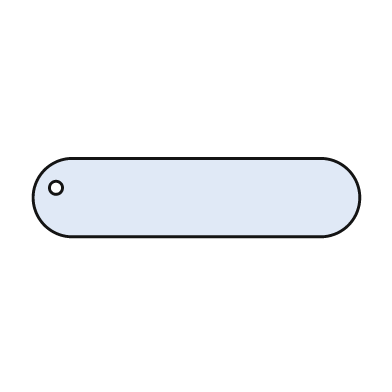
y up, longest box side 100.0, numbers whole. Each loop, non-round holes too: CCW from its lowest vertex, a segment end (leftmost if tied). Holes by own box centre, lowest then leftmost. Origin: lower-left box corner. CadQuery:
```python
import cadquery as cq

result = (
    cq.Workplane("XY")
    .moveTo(12.0, 0.0)
    .lineTo(88.0, 0.0)
    .threePointArc((100.0, 12.0), (88.0, 24.0))
    .lineTo(12.0, 24.0)
    .threePointArc((0.0, 12.0), (12.0, 0.0))
    .close()
    .moveTo(7.0, 15.0)
    .circle(2.0)
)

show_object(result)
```